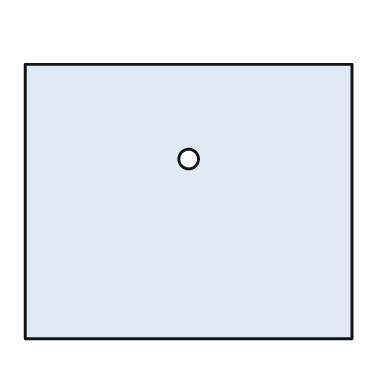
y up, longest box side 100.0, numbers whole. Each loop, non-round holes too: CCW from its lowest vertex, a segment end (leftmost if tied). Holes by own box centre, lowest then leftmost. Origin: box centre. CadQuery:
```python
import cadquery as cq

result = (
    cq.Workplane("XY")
    .moveTo(-50.0, -42.0)
    .lineTo(50.0, -42.0)
    .lineTo(50.0, 42.0)
    .lineTo(-50.0, 42.0)
    .close()
    .moveTo(0.0, 13.0)
    .circle(3.0)
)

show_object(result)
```